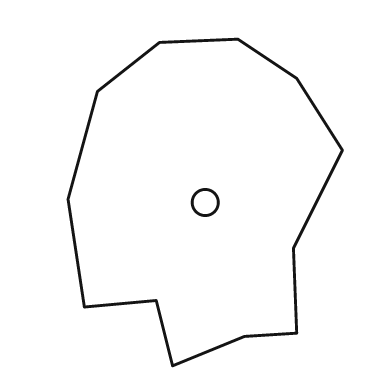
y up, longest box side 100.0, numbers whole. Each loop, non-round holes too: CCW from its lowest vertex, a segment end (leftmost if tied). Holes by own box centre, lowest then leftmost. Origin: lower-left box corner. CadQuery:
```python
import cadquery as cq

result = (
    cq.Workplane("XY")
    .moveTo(32.0, 0.0)
    .lineTo(54.0, 9.0)
    .lineTo(70.0, 10.0)
    .lineTo(69.0, 36.0)
    .lineTo(84.0, 66.0)
    .lineTo(70.0, 88.0)
    .lineTo(52.0, 100.0)
    .lineTo(28.0, 99.0)
    .lineTo(9.0, 84.0)
    .lineTo(0.0, 51.0)
    .lineTo(5.0, 18.0)
    .lineTo(27.0, 20.0)
    .close()
    .moveTo(42.0, 50.0)
    .circle(4.0)
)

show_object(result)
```